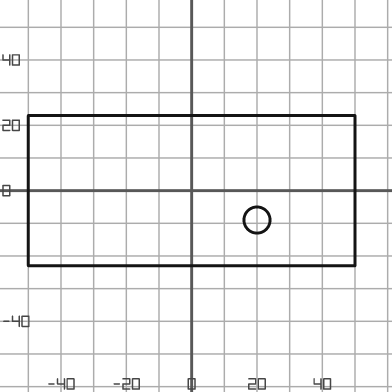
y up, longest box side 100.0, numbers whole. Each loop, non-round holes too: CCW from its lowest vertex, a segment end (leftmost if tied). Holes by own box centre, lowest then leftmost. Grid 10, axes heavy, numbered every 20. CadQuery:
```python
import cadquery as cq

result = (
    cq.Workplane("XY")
    .moveTo(-50.0, -23.0)
    .lineTo(50.0, -23.0)
    .lineTo(50.0, 23.0)
    .lineTo(-50.0, 23.0)
    .close()
    .moveTo(20.0, -9.0)
    .circle(4.0)
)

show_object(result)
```